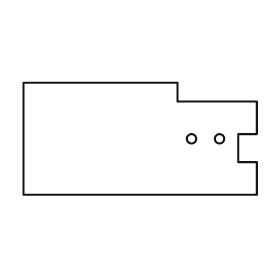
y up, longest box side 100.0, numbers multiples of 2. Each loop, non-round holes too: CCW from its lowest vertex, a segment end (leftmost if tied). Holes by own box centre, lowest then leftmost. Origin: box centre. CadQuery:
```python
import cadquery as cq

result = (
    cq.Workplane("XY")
    .moveTo(-50.0, -24.0)
    .lineTo(50.0, -24.0)
    .lineTo(50.0, -10.0)
    .lineTo(42.0, -10.0)
    .lineTo(42.0, 2.0)
    .lineTo(50.0, 2.0)
    .lineTo(50.0, 16.0)
    .lineTo(16.0, 16.0)
    .lineTo(16.0, 24.0)
    .lineTo(-50.0, 24.0)
    .close()
    .moveTo(22.0, 0.0)
    .circle(2.0)
    .moveTo(34.0, 0.0)
    .circle(2.0)
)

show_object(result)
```